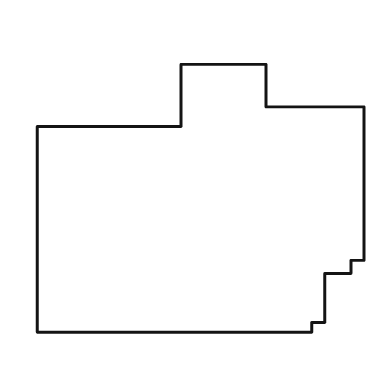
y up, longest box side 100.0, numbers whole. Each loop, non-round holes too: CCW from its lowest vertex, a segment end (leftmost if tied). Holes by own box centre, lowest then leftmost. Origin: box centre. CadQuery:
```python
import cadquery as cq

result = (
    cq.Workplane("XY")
    .moveTo(-50.0, -41.0)
    .lineTo(34.0, -41.0)
    .lineTo(34.0, -38.0)
    .lineTo(38.0, -38.0)
    .lineTo(38.0, -23.0)
    .lineTo(46.0, -23.0)
    .lineTo(46.0, -19.0)
    .lineTo(50.0, -19.0)
    .lineTo(50.0, 28.0)
    .lineTo(20.0, 28.0)
    .lineTo(20.0, 41.0)
    .lineTo(-6.0, 41.0)
    .lineTo(-6.0, 22.0)
    .lineTo(-50.0, 22.0)
    .close()
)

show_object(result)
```